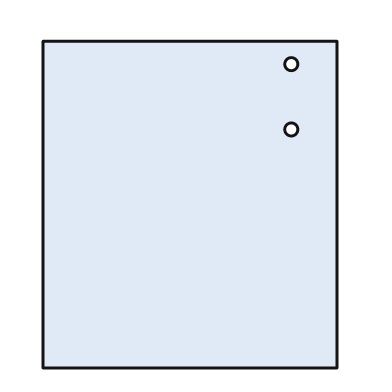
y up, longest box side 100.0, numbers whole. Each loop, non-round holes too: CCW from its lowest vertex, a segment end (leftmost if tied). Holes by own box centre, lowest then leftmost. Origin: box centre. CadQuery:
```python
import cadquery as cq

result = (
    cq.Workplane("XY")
    .moveTo(-45.0, -50.0)
    .lineTo(45.0, -50.0)
    .lineTo(45.0, 50.0)
    .lineTo(-45.0, 50.0)
    .close()
    .moveTo(31.0, 23.0)
    .circle(2.0)
    .moveTo(31.0, 43.0)
    .circle(2.0)
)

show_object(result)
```